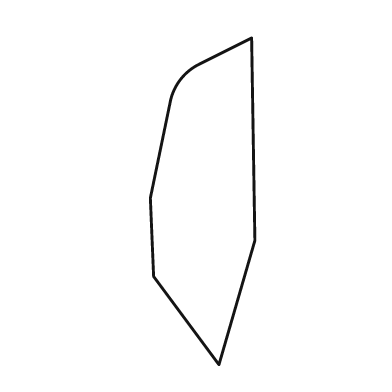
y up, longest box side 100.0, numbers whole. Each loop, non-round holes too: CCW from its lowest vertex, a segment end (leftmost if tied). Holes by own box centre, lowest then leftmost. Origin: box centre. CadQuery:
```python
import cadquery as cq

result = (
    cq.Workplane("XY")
    .moveTo(5.0, -50.0)
    .lineTo(16.0, -12.0)
    .lineTo(15.0, 50.0)
    .lineTo(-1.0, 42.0)
    .threePointArc((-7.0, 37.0), (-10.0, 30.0))
    .lineTo(-16.0, 1.0)
    .lineTo(-15.0, -23.0)
    .close()
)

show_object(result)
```